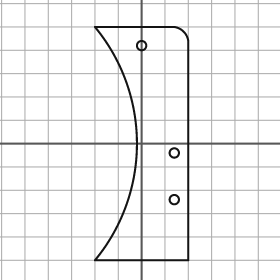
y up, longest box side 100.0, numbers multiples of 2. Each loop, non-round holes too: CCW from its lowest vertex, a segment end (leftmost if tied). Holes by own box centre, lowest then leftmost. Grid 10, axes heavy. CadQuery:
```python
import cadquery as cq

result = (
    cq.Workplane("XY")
    .moveTo(-20.0, -50.0)
    .lineTo(20.0, -50.0)
    .lineTo(20.0, 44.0)
    .threePointArc((18.0, 48.0), (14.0, 50.0))
    .lineTo(-20.0, 50.0)
    .threePointArc((-2.0, 0.0), (-20.0, -50.0))
    .close()
    .moveTo(14.0, -24.0)
    .circle(2.0)
    .moveTo(14.0, -4.0)
    .circle(2.0)
    .moveTo(0.0, 42.0)
    .circle(2.0)
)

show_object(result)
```